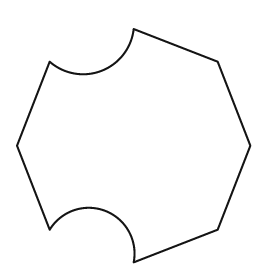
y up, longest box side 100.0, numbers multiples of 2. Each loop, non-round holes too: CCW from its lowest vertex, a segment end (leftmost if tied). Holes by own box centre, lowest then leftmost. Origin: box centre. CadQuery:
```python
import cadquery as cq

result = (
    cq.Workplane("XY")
    .moveTo(0.0, -50.0)
    .lineTo(36.0, -36.0)
    .lineTo(50.0, 0.0)
    .lineTo(36.0, 36.0)
    .lineTo(0.0, 50.0)
    .threePointArc((-14.0, 32.0), (-36.0, 36.0))
    .lineTo(-50.0, 0.0)
    .lineTo(-36.0, -36.0)
    .threePointArc((-12.0, -28.0), (0.0, -50.0))
    .close()
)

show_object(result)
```